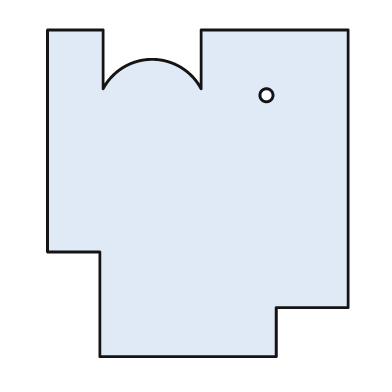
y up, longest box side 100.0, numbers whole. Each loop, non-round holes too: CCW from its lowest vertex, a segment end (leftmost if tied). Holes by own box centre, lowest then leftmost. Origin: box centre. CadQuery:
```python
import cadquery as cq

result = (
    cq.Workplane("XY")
    .moveTo(-30.0, -50.0)
    .lineTo(24.0, -50.0)
    .lineTo(24.0, -35.0)
    .lineTo(46.0, -35.0)
    .lineTo(46.0, 50.0)
    .lineTo(1.0, 50.0)
    .lineTo(1.0, 32.0)
    .threePointArc((-14.0, 41.0), (-29.0, 32.0))
    .lineTo(-29.0, 50.0)
    .lineTo(-46.0, 50.0)
    .lineTo(-46.0, -18.0)
    .lineTo(-30.0, -18.0)
    .close()
    .moveTo(21.0, 30.0)
    .circle(2.0)
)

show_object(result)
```